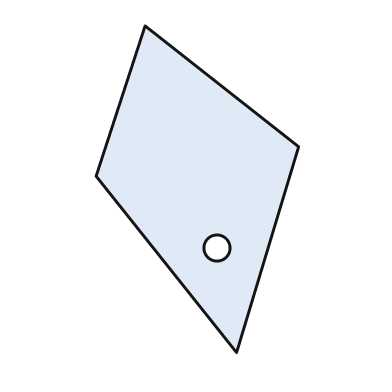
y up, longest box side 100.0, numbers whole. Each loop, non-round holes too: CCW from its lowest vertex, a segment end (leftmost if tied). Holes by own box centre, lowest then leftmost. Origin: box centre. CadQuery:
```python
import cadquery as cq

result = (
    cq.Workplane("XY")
    .moveTo(12.0, -50.0)
    .lineTo(31.0, 13.0)
    .lineTo(-16.0, 50.0)
    .lineTo(-31.0, 4.0)
    .close()
    .moveTo(6.0, -18.0)
    .circle(4.0)
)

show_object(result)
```